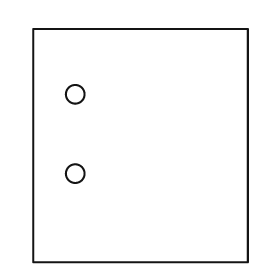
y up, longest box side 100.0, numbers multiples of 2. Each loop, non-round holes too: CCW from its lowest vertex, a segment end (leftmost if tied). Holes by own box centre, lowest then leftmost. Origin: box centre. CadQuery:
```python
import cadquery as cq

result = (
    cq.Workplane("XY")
    .moveTo(-46.0, -50.0)
    .lineTo(46.0, -50.0)
    .lineTo(46.0, 50.0)
    .lineTo(-46.0, 50.0)
    .close()
    .moveTo(-28.0, -12.0)
    .circle(4.0)
    .moveTo(-28.0, 22.0)
    .circle(4.0)
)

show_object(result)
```